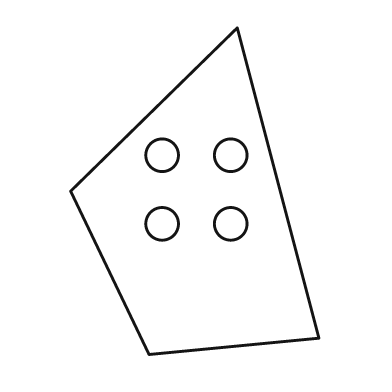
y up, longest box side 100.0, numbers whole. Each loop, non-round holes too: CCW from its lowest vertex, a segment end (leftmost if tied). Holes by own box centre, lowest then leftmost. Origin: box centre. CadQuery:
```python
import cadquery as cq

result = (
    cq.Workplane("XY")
    .moveTo(-14.0, -50.0)
    .lineTo(38.0, -45.0)
    .lineTo(13.0, 50.0)
    .lineTo(-38.0, 0.0)
    .close()
    .moveTo(-10.0, -10.0)
    .circle(5.0)
    .moveTo(11.0, -10.0)
    .circle(5.0)
    .moveTo(-10.0, 11.0)
    .circle(5.0)
    .moveTo(11.0, 11.0)
    .circle(5.0)
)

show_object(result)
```